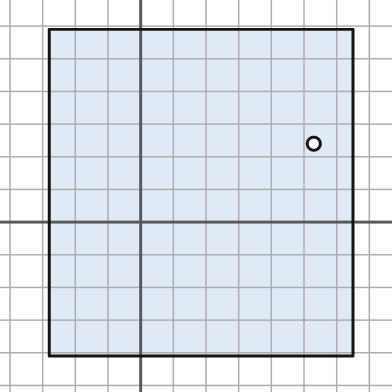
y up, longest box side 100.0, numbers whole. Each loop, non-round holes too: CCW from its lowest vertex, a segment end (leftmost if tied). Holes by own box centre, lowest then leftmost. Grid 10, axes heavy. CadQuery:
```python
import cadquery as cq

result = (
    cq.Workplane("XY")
    .moveTo(-28.0, -41.0)
    .lineTo(65.0, -41.0)
    .lineTo(65.0, 59.0)
    .lineTo(-28.0, 59.0)
    .close()
    .moveTo(53.0, 24.0)
    .circle(2.0)
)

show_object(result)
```